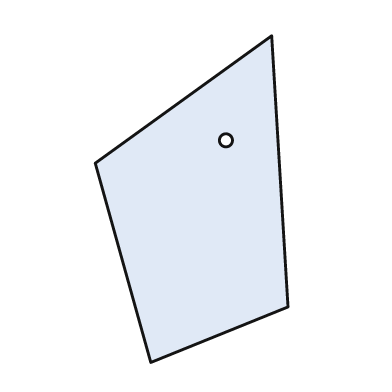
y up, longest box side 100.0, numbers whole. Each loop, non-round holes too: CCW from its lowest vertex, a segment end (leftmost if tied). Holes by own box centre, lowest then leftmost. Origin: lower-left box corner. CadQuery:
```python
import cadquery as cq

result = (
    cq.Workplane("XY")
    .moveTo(17.0, 0.0)
    .lineTo(59.0, 17.0)
    .lineTo(54.0, 100.0)
    .lineTo(0.0, 61.0)
    .close()
    .moveTo(40.0, 68.0)
    .circle(2.0)
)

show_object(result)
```